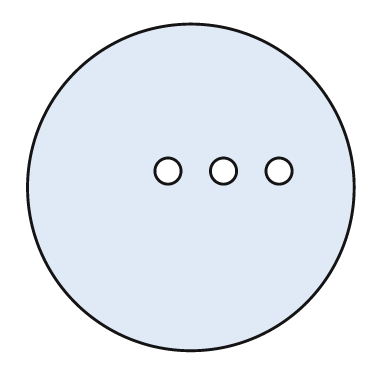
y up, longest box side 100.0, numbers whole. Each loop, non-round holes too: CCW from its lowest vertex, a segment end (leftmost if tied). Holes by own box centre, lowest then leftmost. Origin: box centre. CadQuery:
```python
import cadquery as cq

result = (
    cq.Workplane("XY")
    .moveTo(0.0, 0.0)
    .circle(50.0)
    .moveTo(-7.0, 5.0)
    .circle(4.0)
    .moveTo(10.0, 5.0)
    .circle(4.0)
    .moveTo(27.0, 5.0)
    .circle(4.0)
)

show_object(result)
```